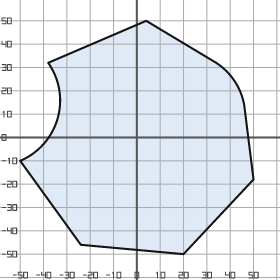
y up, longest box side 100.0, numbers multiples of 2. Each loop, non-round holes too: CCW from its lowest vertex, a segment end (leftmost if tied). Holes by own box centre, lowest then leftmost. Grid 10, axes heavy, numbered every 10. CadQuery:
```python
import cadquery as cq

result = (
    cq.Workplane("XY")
    .moveTo(20.0, -50.0)
    .lineTo(50.0, -18.0)
    .lineTo(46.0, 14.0)
    .threePointArc((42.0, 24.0), (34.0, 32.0))
    .lineTo(4.0, 50.0)
    .lineTo(-38.0, 32.0)
    .threePointArc((-34.0, 8.0), (-50.0, -10.0))
    .lineTo(-24.0, -46.0)
    .close()
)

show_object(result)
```